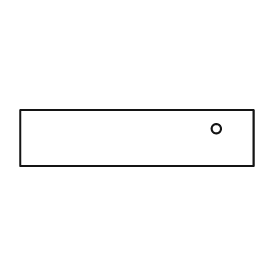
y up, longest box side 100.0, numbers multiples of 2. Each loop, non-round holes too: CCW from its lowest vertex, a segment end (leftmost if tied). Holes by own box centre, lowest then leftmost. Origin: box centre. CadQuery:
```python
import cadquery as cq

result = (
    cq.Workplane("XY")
    .moveTo(-50.0, -12.0)
    .lineTo(50.0, -12.0)
    .lineTo(50.0, 12.0)
    .lineTo(-50.0, 12.0)
    .close()
    .moveTo(34.0, 4.0)
    .circle(2.0)
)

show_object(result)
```